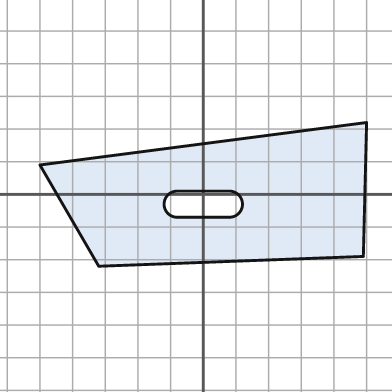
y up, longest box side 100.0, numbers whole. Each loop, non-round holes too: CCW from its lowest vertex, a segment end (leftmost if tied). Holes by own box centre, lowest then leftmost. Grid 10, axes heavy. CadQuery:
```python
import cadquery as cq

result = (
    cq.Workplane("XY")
    .moveTo(-32.0, -22.0)
    .lineTo(49.0, -19.0)
    .lineTo(50.0, 22.0)
    .lineTo(-50.0, 9.0)
    .close()
    .moveTo(-8.0, -7.0)
    .lineTo(8.0, -7.0)
    .threePointArc((12.0, -3.0), (8.0, 1.0))
    .lineTo(-8.0, 1.0)
    .threePointArc((-12.0, -3.0), (-8.0, -7.0))
    .close()
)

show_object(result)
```